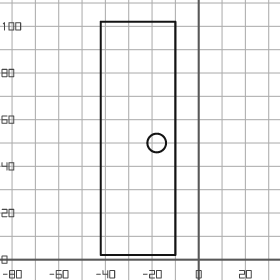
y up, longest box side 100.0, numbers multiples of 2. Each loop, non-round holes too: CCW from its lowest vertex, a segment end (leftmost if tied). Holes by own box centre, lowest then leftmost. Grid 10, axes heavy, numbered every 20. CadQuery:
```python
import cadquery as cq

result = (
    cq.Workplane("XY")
    .moveTo(-42.0, 2.0)
    .lineTo(-10.0, 2.0)
    .lineTo(-10.0, 102.0)
    .lineTo(-42.0, 102.0)
    .close()
    .moveTo(-18.0, 50.0)
    .circle(4.0)
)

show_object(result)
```